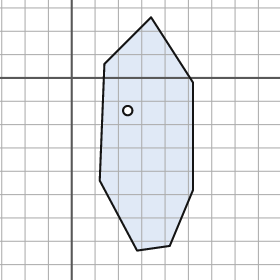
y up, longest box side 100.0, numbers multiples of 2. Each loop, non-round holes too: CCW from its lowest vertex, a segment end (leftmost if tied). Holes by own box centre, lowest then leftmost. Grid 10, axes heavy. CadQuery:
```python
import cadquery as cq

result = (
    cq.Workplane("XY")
    .moveTo(28.0, -74.0)
    .lineTo(42.0, -72.0)
    .lineTo(52.0, -48.0)
    .lineTo(52.0, -2.0)
    .lineTo(34.0, 26.0)
    .lineTo(14.0, 6.0)
    .lineTo(12.0, -44.0)
    .close()
    .moveTo(24.0, -14.0)
    .circle(2.0)
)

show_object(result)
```